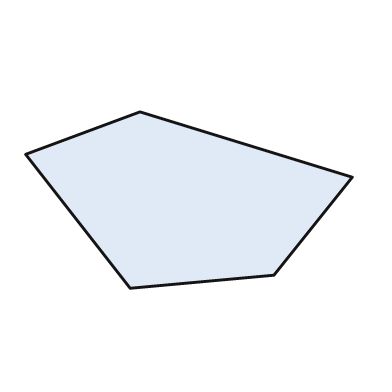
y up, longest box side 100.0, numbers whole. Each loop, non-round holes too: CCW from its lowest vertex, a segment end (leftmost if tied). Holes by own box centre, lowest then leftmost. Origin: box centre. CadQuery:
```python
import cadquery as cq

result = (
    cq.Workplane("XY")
    .moveTo(-18.0, -27.0)
    .lineTo(26.0, -23.0)
    .lineTo(50.0, 7.0)
    .lineTo(-15.0, 27.0)
    .lineTo(-50.0, 14.0)
    .close()
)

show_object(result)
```